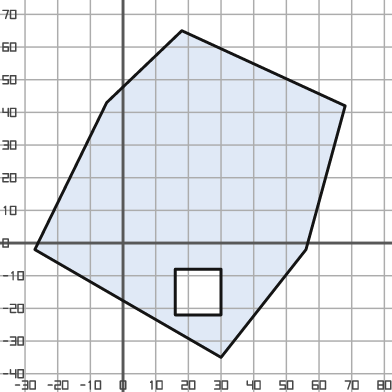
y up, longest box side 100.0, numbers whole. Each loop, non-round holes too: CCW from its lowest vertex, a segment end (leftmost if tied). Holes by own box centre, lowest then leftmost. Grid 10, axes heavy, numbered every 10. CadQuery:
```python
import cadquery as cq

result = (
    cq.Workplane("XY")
    .moveTo(30.0, -35.0)
    .lineTo(56.0, -2.0)
    .lineTo(68.0, 42.0)
    .lineTo(18.0, 65.0)
    .lineTo(-5.0, 43.0)
    .lineTo(-27.0, -2.0)
    .close()
    .moveTo(16.0, -22.0)
    .lineTo(30.0, -22.0)
    .lineTo(30.0, -8.0)
    .lineTo(16.0, -8.0)
    .close()
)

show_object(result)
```